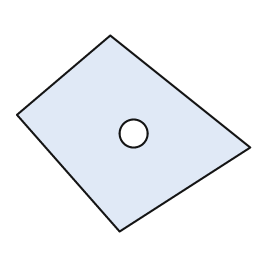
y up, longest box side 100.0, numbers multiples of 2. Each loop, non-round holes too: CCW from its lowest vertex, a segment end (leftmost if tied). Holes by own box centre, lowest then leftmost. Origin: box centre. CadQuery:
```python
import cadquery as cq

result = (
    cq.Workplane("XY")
    .moveTo(-6.0, -42.0)
    .lineTo(50.0, -6.0)
    .lineTo(-10.0, 42.0)
    .lineTo(-50.0, 8.0)
    .close()
    .moveTo(0.0, 0.0)
    .circle(6.0)
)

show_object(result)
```